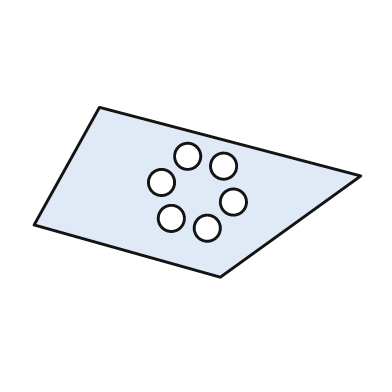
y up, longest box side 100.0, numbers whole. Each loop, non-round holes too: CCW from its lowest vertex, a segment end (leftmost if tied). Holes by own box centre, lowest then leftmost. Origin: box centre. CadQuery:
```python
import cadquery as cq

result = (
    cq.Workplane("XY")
    .moveTo(7.0, -26.0)
    .lineTo(50.0, 5.0)
    .lineTo(-30.0, 26.0)
    .lineTo(-50.0, -10.0)
    .close()
    .moveTo(3.0, -11.0)
    .circle(4.0)
    .moveTo(-8.0, -8.0)
    .circle(4.0)
    .moveTo(11.0, -3.0)
    .circle(4.0)
    .moveTo(-11.0, 3.0)
    .circle(4.0)
    .moveTo(8.0, 8.0)
    .circle(4.0)
    .moveTo(-3.0, 11.0)
    .circle(4.0)
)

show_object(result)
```